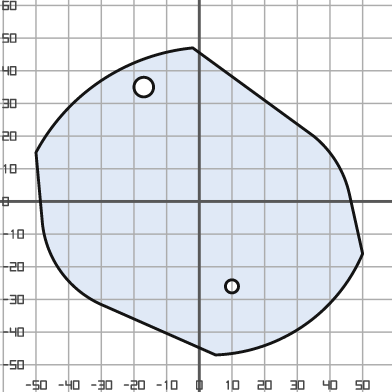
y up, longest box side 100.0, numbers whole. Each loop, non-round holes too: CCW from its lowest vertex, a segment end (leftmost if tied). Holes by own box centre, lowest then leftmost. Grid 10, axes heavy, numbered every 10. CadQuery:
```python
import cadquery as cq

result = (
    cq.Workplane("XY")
    .moveTo(5.0, -47.0)
    .threePointArc((32.0, -38.0), (50.0, -16.0))
    .lineTo(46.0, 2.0)
    .threePointArc((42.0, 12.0), (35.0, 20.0))
    .lineTo(-2.0, 47.0)
    .threePointArc((-30.0, 37.0), (-50.0, 15.0))
    .lineTo(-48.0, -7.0)
    .threePointArc((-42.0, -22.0), (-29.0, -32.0))
    .close()
    .moveTo(10.0, -26.0)
    .circle(2.0)
    .moveTo(-17.0, 35.0)
    .circle(3.0)
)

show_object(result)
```